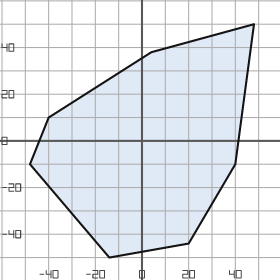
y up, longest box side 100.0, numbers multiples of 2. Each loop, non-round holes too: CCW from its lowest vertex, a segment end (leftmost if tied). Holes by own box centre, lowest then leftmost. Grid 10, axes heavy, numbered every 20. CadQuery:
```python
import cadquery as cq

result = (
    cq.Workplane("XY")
    .moveTo(-14.0, -50.0)
    .lineTo(20.0, -44.0)
    .lineTo(40.0, -10.0)
    .lineTo(48.0, 50.0)
    .lineTo(4.0, 38.0)
    .lineTo(-40.0, 10.0)
    .lineTo(-48.0, -10.0)
    .close()
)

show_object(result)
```